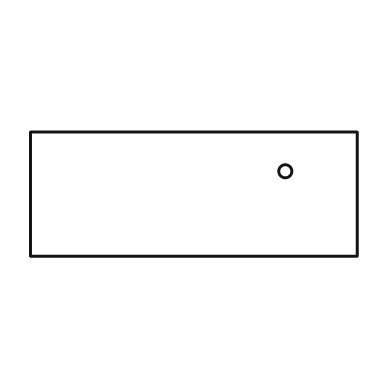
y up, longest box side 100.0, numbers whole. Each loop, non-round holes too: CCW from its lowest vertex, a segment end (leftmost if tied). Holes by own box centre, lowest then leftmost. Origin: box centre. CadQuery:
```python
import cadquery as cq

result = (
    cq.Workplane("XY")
    .moveTo(-50.0, -19.0)
    .lineTo(50.0, -19.0)
    .lineTo(50.0, 19.0)
    .lineTo(-50.0, 19.0)
    .close()
    .moveTo(28.0, 7.0)
    .circle(2.0)
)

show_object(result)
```